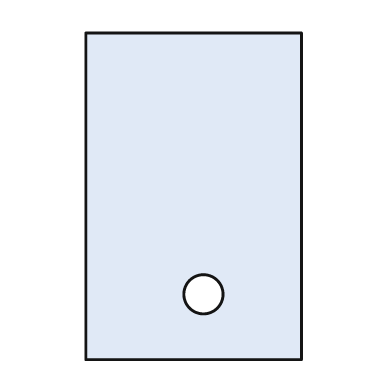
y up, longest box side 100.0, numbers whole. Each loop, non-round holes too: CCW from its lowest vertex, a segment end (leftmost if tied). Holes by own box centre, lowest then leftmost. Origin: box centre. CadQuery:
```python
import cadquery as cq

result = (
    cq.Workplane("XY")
    .moveTo(-33.0, -50.0)
    .lineTo(33.0, -50.0)
    .lineTo(33.0, 50.0)
    .lineTo(-33.0, 50.0)
    .close()
    .moveTo(3.0, -30.0)
    .circle(6.0)
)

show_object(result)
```